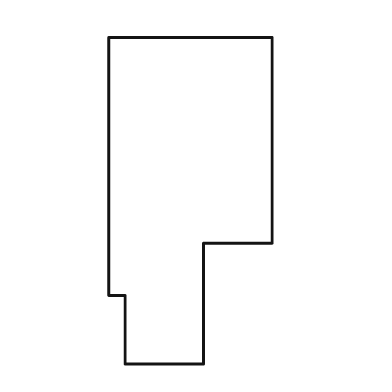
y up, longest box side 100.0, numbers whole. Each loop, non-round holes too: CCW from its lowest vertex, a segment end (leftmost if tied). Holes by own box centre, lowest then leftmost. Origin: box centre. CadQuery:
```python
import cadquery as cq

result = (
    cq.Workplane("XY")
    .moveTo(-20.0, -50.0)
    .lineTo(4.0, -50.0)
    .lineTo(4.0, -13.0)
    .lineTo(25.0, -13.0)
    .lineTo(25.0, 50.0)
    .lineTo(-25.0, 50.0)
    .lineTo(-25.0, -29.0)
    .lineTo(-20.0, -29.0)
    .close()
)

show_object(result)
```